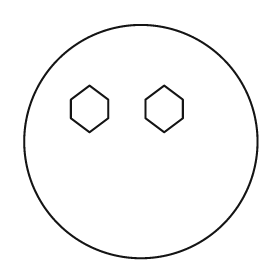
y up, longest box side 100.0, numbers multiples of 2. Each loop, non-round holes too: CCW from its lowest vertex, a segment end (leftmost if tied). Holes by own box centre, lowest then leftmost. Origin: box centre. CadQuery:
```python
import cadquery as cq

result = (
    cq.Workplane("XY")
    .moveTo(0.0, 0.0)
    .circle(50.0)
    .moveTo(-22.0, 4.0)
    .lineTo(-14.0, 10.0)
    .lineTo(-14.0, 18.0)
    .lineTo(-22.0, 24.0)
    .lineTo(-30.0, 18.0)
    .lineTo(-30.0, 10.0)
    .close()
    .moveTo(10.0, 4.0)
    .lineTo(18.0, 10.0)
    .lineTo(18.0, 18.0)
    .lineTo(10.0, 24.0)
    .lineTo(2.0, 18.0)
    .lineTo(2.0, 10.0)
    .close()
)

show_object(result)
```